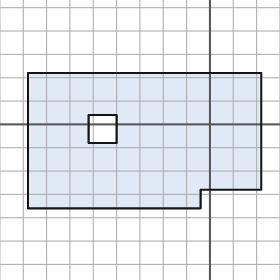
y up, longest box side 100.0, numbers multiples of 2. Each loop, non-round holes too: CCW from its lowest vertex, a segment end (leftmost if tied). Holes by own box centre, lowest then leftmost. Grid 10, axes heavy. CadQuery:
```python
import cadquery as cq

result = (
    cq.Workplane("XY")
    .moveTo(-78.0, -36.0)
    .lineTo(-4.0, -36.0)
    .lineTo(-4.0, -28.0)
    .lineTo(22.0, -28.0)
    .lineTo(22.0, 22.0)
    .lineTo(-78.0, 22.0)
    .close()
    .moveTo(-52.0, -8.0)
    .lineTo(-40.0, -8.0)
    .lineTo(-40.0, 4.0)
    .lineTo(-52.0, 4.0)
    .close()
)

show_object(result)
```